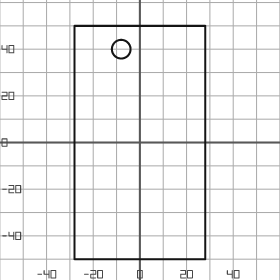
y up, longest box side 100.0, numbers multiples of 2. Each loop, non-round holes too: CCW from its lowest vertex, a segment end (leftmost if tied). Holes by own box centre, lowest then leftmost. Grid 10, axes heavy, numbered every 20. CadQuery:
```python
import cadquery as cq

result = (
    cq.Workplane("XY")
    .moveTo(-28.0, -50.0)
    .lineTo(28.0, -50.0)
    .lineTo(28.0, 50.0)
    .lineTo(-28.0, 50.0)
    .close()
    .moveTo(-8.0, 40.0)
    .circle(4.0)
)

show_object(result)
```